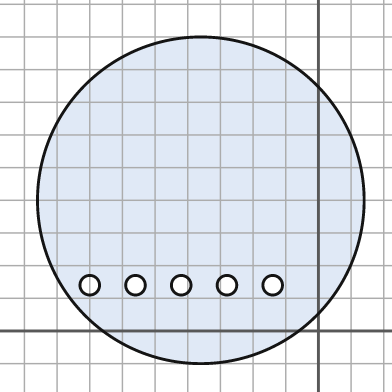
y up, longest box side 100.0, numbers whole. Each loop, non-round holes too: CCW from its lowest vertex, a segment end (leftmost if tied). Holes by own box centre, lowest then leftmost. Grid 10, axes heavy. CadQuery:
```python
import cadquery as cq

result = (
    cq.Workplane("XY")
    .moveTo(-36.0, 40.0)
    .circle(50.0)
    .moveTo(-70.0, 14.0)
    .circle(3.0)
    .moveTo(-56.0, 14.0)
    .circle(3.0)
    .moveTo(-42.0, 14.0)
    .circle(3.0)
    .moveTo(-28.0, 14.0)
    .circle(3.0)
    .moveTo(-14.0, 14.0)
    .circle(3.0)
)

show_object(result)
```